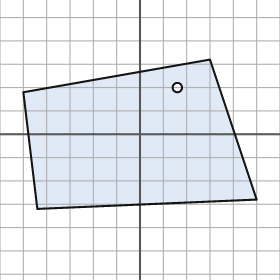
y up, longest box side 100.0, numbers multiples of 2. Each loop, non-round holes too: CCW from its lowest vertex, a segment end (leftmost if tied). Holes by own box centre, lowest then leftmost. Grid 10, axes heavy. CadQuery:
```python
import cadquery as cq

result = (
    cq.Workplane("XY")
    .moveTo(-44.0, -32.0)
    .lineTo(50.0, -28.0)
    .lineTo(30.0, 32.0)
    .lineTo(-50.0, 18.0)
    .close()
    .moveTo(16.0, 20.0)
    .circle(2.0)
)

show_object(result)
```